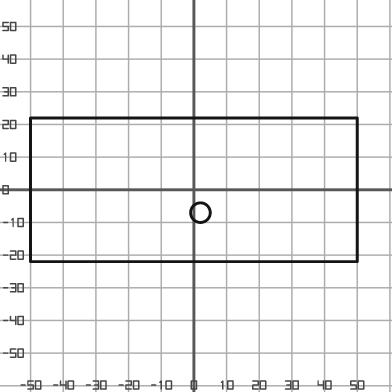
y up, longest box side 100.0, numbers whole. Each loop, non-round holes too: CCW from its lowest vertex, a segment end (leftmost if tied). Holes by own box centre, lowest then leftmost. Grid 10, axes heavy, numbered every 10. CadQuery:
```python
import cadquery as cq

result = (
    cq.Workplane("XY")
    .moveTo(-50.0, -22.0)
    .lineTo(50.0, -22.0)
    .lineTo(50.0, 22.0)
    .lineTo(-50.0, 22.0)
    .close()
    .moveTo(2.0, -7.0)
    .circle(3.0)
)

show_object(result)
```